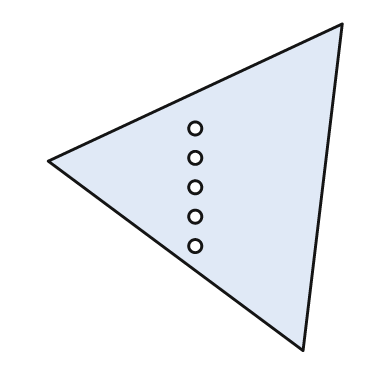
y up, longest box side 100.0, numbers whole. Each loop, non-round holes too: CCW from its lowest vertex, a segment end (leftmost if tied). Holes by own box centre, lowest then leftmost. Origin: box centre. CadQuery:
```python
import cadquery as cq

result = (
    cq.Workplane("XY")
    .moveTo(33.0, -50.0)
    .lineTo(45.0, 50.0)
    .lineTo(-45.0, 8.0)
    .close()
    .moveTo(0.0, -18.0)
    .circle(2.0)
    .moveTo(0.0, -9.0)
    .circle(2.0)
    .moveTo(0.0, 0.0)
    .circle(2.0)
    .moveTo(0.0, 9.0)
    .circle(2.0)
    .moveTo(0.0, 18.0)
    .circle(2.0)
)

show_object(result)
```